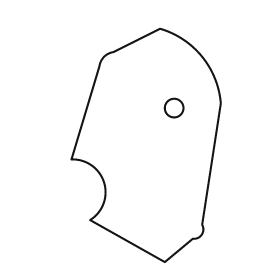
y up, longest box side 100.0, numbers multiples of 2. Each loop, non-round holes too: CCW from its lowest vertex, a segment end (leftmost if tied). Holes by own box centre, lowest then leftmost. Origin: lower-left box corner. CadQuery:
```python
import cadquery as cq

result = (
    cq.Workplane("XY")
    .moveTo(40.0, 0.0)
    .lineTo(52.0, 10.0)
    .threePointArc((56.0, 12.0), (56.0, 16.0))
    .lineTo(64.0, 68.0)
    .threePointArc((56.0, 88.0), (38.0, 100.0))
    .lineTo(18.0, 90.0)
    .threePointArc((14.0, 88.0), (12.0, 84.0))
    .lineTo(0.0, 44.0)
    .threePointArc((14.0, 34.0), (8.0, 18.0))
    .close()
    .moveTo(44.0, 66.0)
    .circle(4.0)
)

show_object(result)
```